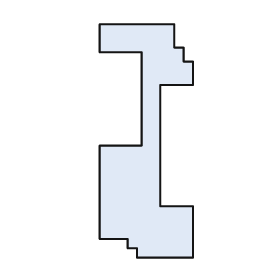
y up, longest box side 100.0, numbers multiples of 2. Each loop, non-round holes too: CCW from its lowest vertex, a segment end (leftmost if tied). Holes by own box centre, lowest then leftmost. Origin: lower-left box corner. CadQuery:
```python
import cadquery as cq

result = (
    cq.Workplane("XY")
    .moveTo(16.0, 0.0)
    .lineTo(40.0, 0.0)
    .lineTo(40.0, 22.0)
    .lineTo(26.0, 22.0)
    .lineTo(26.0, 74.0)
    .lineTo(40.0, 74.0)
    .lineTo(40.0, 84.0)
    .lineTo(36.0, 84.0)
    .lineTo(36.0, 90.0)
    .lineTo(32.0, 90.0)
    .lineTo(32.0, 100.0)
    .lineTo(0.0, 100.0)
    .lineTo(0.0, 88.0)
    .lineTo(18.0, 88.0)
    .lineTo(18.0, 48.0)
    .lineTo(0.0, 48.0)
    .lineTo(0.0, 8.0)
    .lineTo(12.0, 8.0)
    .lineTo(12.0, 4.0)
    .lineTo(16.0, 4.0)
    .close()
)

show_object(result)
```